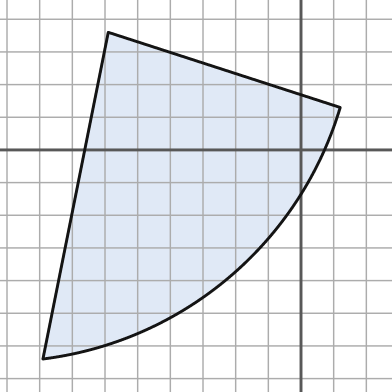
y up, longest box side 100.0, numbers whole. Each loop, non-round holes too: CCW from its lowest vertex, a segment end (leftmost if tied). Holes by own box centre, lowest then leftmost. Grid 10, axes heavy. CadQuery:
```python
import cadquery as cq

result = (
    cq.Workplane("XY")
    .moveTo(-79.0, -64.0)
    .threePointArc((-22.0, -39.0), (12.0, 13.0))
    .lineTo(-59.0, 36.0)
    .close()
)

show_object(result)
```